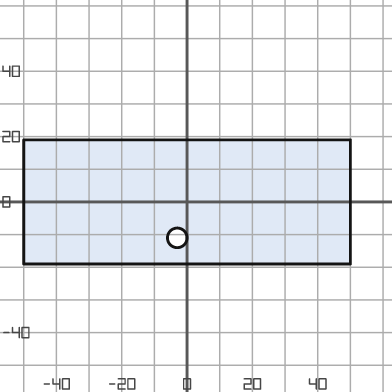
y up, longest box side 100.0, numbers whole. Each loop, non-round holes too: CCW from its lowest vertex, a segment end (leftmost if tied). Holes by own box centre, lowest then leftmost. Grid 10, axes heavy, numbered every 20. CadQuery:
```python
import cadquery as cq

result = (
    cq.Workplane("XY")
    .moveTo(-50.0, -19.0)
    .lineTo(50.0, -19.0)
    .lineTo(50.0, 19.0)
    .lineTo(-50.0, 19.0)
    .close()
    .moveTo(-3.0, -11.0)
    .circle(3.0)
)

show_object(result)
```